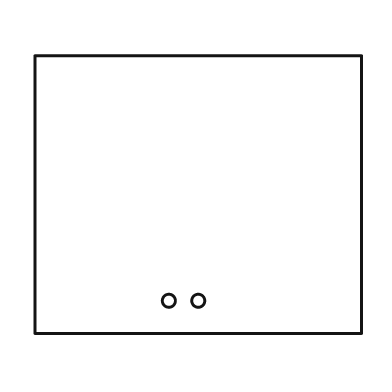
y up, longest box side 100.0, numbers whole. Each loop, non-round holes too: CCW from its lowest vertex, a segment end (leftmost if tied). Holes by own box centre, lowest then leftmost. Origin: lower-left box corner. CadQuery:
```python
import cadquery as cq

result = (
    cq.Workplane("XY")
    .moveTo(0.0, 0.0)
    .lineTo(100.0, 0.0)
    .lineTo(100.0, 85.0)
    .lineTo(0.0, 85.0)
    .close()
    .moveTo(41.0, 10.0)
    .circle(2.0)
    .moveTo(50.0, 10.0)
    .circle(2.0)
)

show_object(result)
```